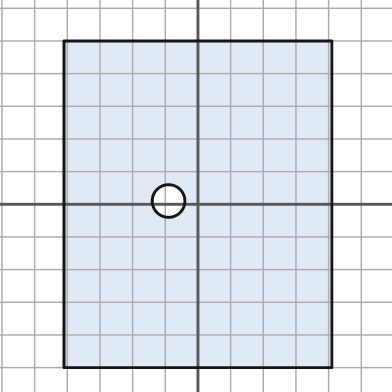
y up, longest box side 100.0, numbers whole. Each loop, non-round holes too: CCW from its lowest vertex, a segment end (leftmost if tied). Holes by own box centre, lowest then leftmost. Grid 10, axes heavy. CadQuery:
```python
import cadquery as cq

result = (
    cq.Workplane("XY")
    .moveTo(-41.0, -50.0)
    .lineTo(41.0, -50.0)
    .lineTo(41.0, 50.0)
    .lineTo(-41.0, 50.0)
    .close()
    .moveTo(-9.0, 1.0)
    .circle(5.0)
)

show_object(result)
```